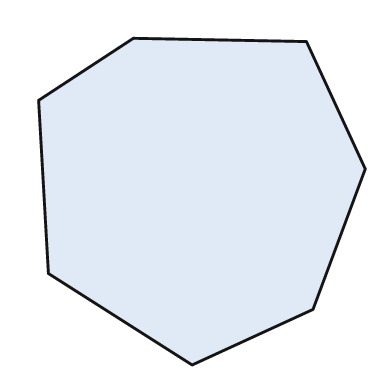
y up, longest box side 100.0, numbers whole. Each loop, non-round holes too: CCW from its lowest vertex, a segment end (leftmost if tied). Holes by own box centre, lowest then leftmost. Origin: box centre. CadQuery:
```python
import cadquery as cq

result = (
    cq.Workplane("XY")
    .moveTo(-3.0, -50.0)
    .lineTo(34.0, -33.0)
    .lineTo(50.0, 10.0)
    .lineTo(32.0, 49.0)
    .lineTo(-21.0, 50.0)
    .lineTo(-50.0, 31.0)
    .lineTo(-47.0, -22.0)
    .close()
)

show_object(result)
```